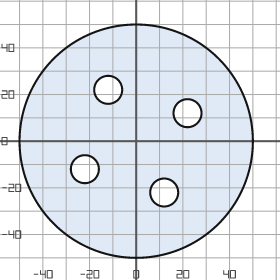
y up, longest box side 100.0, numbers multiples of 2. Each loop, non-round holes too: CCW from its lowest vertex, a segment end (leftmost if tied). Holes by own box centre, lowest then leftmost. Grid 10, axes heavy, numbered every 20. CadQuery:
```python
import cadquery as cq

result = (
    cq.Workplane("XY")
    .moveTo(0.0, 0.0)
    .circle(50.0)
    .moveTo(12.0, -22.0)
    .circle(6.0)
    .moveTo(-22.0, -12.0)
    .circle(6.0)
    .moveTo(22.0, 12.0)
    .circle(6.0)
    .moveTo(-12.0, 22.0)
    .circle(6.0)
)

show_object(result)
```